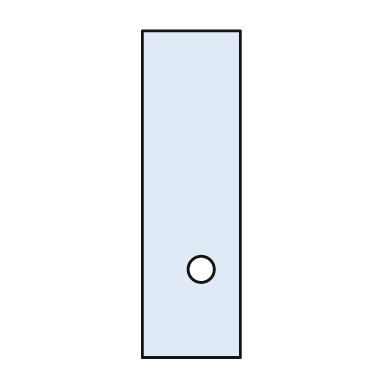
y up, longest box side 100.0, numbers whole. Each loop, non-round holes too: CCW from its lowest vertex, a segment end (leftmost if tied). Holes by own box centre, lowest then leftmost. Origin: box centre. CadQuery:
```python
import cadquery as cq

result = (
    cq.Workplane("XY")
    .moveTo(-15.0, -50.0)
    .lineTo(15.0, -50.0)
    .lineTo(15.0, 50.0)
    .lineTo(-15.0, 50.0)
    .close()
    .moveTo(3.0, -23.0)
    .circle(4.0)
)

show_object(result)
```